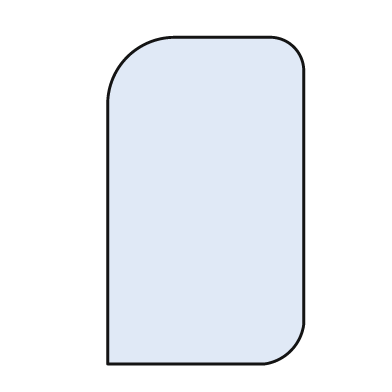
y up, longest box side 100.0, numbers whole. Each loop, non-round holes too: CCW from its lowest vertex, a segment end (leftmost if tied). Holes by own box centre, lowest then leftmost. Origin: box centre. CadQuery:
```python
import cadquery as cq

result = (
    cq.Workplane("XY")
    .moveTo(-30.0, -50.0)
    .lineTo(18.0, -50.0)
    .threePointArc((26.0, -46.0), (30.0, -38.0))
    .lineTo(30.0, 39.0)
    .threePointArc((27.0, 47.0), (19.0, 50.0))
    .lineTo(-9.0, 50.0)
    .threePointArc((-24.0, 44.0), (-30.0, 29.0))
    .close()
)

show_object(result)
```